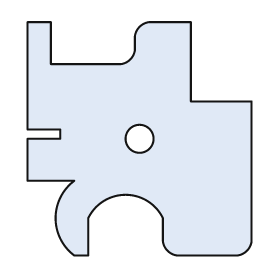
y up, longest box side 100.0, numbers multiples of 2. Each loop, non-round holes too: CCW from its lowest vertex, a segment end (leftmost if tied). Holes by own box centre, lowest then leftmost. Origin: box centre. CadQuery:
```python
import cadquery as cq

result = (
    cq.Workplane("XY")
    .moveTo(-28.0, -50.0)
    .lineTo(-22.0, -50.0)
    .lineTo(-22.0, -34.0)
    .threePointArc((-6.0, -24.0), (10.0, -34.0))
    .lineTo(10.0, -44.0)
    .threePointArc((12.0, -48.0), (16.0, -50.0))
    .lineTo(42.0, -50.0)
    .threePointArc((46.0, -48.0), (48.0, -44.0))
    .lineTo(48.0, 16.0)
    .lineTo(22.0, 16.0)
    .lineTo(22.0, 50.0)
    .lineTo(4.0, 50.0)
    .threePointArc((0.0, 48.0), (-2.0, 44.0))
    .lineTo(-2.0, 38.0)
    .threePointArc((-4.0, 34.0), (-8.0, 32.0))
    .lineTo(-38.0, 32.0)
    .lineTo(-38.0, 50.0)
    .lineTo(-48.0, 50.0)
    .lineTo(-48.0, 4.0)
    .lineTo(-34.0, 4.0)
    .lineTo(-34.0, 0.0)
    .lineTo(-48.0, 0.0)
    .lineTo(-48.0, -18.0)
    .lineTo(-28.0, -18.0)
    .threePointArc((-36.0, -34.0), (-28.0, -50.0))
    .close()
    .moveTo(0.0, 0.0)
    .circle(6.0)
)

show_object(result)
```